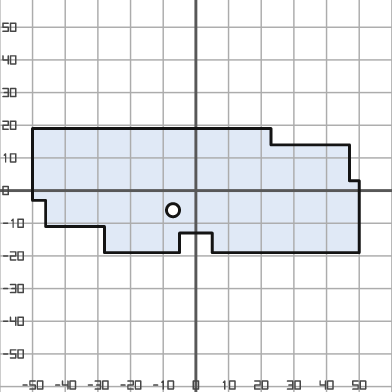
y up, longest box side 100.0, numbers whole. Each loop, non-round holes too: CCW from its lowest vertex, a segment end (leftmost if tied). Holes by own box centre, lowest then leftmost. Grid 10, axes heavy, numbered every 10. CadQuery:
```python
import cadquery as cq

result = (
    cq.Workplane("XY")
    .moveTo(-28.0, -19.0)
    .lineTo(-5.0, -19.0)
    .lineTo(-5.0, -13.0)
    .lineTo(5.0, -13.0)
    .lineTo(5.0, -19.0)
    .lineTo(50.0, -19.0)
    .lineTo(50.0, 3.0)
    .lineTo(47.0, 3.0)
    .lineTo(47.0, 14.0)
    .lineTo(23.0, 14.0)
    .lineTo(23.0, 19.0)
    .lineTo(-50.0, 19.0)
    .lineTo(-50.0, -3.0)
    .lineTo(-46.0, -3.0)
    .lineTo(-46.0, -11.0)
    .lineTo(-28.0, -11.0)
    .close()
    .moveTo(-7.0, -6.0)
    .circle(2.0)
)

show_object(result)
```